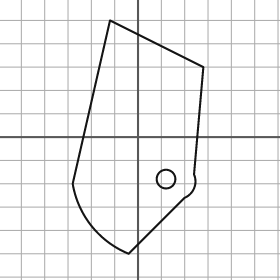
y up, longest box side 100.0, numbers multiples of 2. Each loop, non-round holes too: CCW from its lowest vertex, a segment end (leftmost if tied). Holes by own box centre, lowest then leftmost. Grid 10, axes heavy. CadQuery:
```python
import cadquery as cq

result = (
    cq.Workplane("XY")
    .moveTo(-4.0, -50.0)
    .lineTo(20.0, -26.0)
    .threePointArc((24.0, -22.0), (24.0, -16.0))
    .lineTo(28.0, 30.0)
    .lineTo(-12.0, 50.0)
    .lineTo(-28.0, -20.0)
    .threePointArc((-20.0, -38.0), (-4.0, -50.0))
    .close()
    .moveTo(12.0, -18.0)
    .circle(4.0)
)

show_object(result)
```